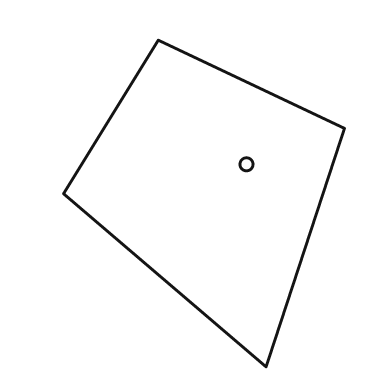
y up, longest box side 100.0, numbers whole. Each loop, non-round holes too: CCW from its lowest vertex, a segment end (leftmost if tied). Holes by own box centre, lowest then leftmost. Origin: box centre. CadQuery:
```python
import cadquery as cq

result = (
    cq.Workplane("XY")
    .moveTo(19.0, -50.0)
    .lineTo(43.0, 23.0)
    .lineTo(-14.0, 50.0)
    .lineTo(-43.0, 3.0)
    .close()
    .moveTo(13.0, 12.0)
    .circle(2.0)
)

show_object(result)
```